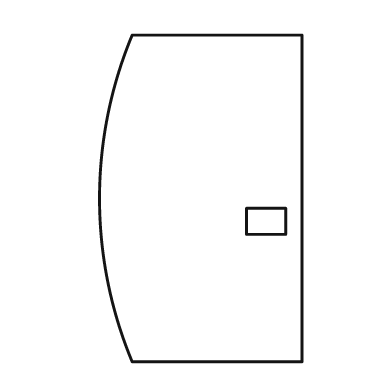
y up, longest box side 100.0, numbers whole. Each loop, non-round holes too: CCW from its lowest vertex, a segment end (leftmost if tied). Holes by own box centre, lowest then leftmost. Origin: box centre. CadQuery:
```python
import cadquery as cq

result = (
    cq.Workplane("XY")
    .moveTo(-21.0, -50.0)
    .lineTo(31.0, -50.0)
    .lineTo(31.0, 50.0)
    .lineTo(-21.0, 50.0)
    .threePointArc((-31.0, 0.0), (-21.0, -50.0))
    .close()
    .moveTo(14.0, -11.0)
    .lineTo(26.0, -11.0)
    .lineTo(26.0, -3.0)
    .lineTo(14.0, -3.0)
    .close()
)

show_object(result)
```